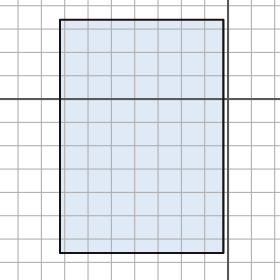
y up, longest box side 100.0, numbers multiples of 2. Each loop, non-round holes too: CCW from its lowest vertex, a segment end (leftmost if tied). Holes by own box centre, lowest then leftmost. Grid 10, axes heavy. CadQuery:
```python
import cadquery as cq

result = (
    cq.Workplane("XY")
    .moveTo(-72.0, -66.0)
    .lineTo(-2.0, -66.0)
    .lineTo(-2.0, 34.0)
    .lineTo(-72.0, 34.0)
    .close()
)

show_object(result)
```